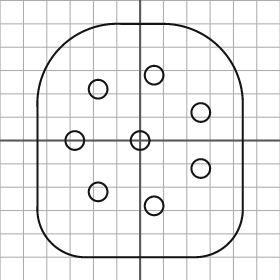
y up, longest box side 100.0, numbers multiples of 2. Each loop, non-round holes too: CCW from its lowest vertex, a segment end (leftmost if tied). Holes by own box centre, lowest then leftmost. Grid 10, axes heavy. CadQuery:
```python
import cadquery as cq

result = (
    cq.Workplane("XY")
    .moveTo(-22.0, -50.0)
    .lineTo(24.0, -50.0)
    .threePointArc((38.0, -44.0), (44.0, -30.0))
    .lineTo(44.0, 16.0)
    .threePointArc((34.0, 40.0), (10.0, 50.0))
    .lineTo(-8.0, 50.0)
    .threePointArc((-34.0, 40.0), (-44.0, 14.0))
    .lineTo(-44.0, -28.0)
    .threePointArc((-38.0, -44.0), (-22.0, -50.0))
    .close()
    .moveTo(6.0, -28.0)
    .circle(4.0)
    .moveTo(-18.0, -22.0)
    .circle(4.0)
    .moveTo(26.0, -12.0)
    .circle(4.0)
    .moveTo(-28.0, 0.0)
    .circle(4.0)
    .moveTo(0.0, 0.0)
    .circle(4.0)
    .moveTo(26.0, 12.0)
    .circle(4.0)
    .moveTo(-18.0, 22.0)
    .circle(4.0)
    .moveTo(6.0, 28.0)
    .circle(4.0)
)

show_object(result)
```